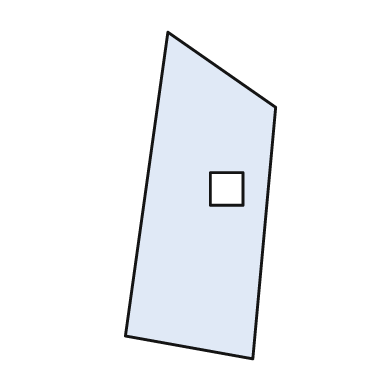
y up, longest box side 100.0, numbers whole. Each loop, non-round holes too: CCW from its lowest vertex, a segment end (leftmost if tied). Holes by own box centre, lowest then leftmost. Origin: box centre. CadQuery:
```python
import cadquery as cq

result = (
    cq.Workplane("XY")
    .moveTo(16.0, -50.0)
    .lineTo(23.0, 27.0)
    .lineTo(-10.0, 50.0)
    .lineTo(-23.0, -43.0)
    .close()
    .moveTo(3.0, -3.0)
    .lineTo(13.0, -3.0)
    .lineTo(13.0, 7.0)
    .lineTo(3.0, 7.0)
    .close()
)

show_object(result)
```